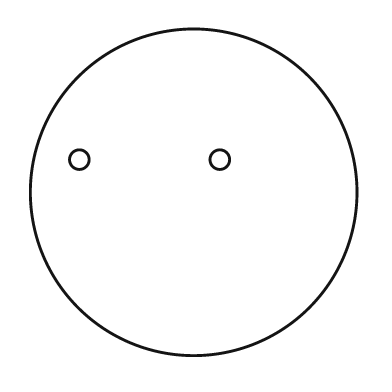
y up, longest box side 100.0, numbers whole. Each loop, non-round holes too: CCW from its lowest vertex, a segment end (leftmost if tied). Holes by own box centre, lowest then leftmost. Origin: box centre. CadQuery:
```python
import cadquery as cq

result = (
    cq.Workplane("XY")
    .moveTo(0.0, 0.0)
    .circle(50.0)
    .moveTo(-35.0, 10.0)
    .circle(3.0)
    .moveTo(8.0, 10.0)
    .circle(3.0)
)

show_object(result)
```